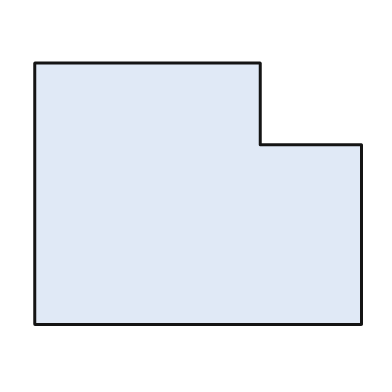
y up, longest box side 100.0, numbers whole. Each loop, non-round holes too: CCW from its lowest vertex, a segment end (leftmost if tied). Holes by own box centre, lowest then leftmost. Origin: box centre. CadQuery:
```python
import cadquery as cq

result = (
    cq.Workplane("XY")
    .moveTo(-50.0, -40.0)
    .lineTo(50.0, -40.0)
    .lineTo(50.0, 15.0)
    .lineTo(19.0, 15.0)
    .lineTo(19.0, 40.0)
    .lineTo(-50.0, 40.0)
    .close()
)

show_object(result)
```